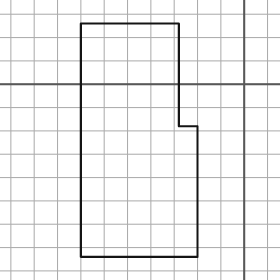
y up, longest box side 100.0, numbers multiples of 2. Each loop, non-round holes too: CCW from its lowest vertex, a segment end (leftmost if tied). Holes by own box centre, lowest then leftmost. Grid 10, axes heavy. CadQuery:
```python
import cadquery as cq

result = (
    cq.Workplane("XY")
    .moveTo(-70.0, -74.0)
    .lineTo(-20.0, -74.0)
    .lineTo(-20.0, -18.0)
    .lineTo(-28.0, -18.0)
    .lineTo(-28.0, 26.0)
    .lineTo(-70.0, 26.0)
    .close()
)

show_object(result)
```